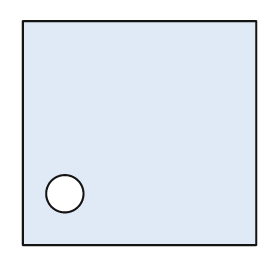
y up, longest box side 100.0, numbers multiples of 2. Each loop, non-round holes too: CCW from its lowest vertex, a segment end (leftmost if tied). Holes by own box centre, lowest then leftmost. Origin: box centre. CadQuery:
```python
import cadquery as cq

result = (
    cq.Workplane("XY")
    .moveTo(-50.0, -48.0)
    .lineTo(50.0, -48.0)
    .lineTo(50.0, 48.0)
    .lineTo(-50.0, 48.0)
    .close()
    .moveTo(-32.0, -26.0)
    .circle(8.0)
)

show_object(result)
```